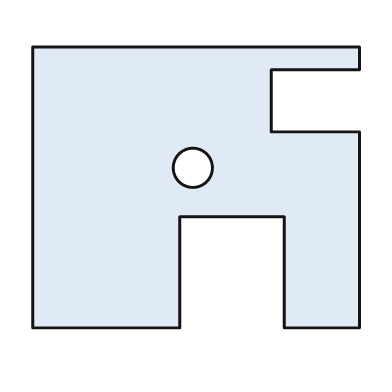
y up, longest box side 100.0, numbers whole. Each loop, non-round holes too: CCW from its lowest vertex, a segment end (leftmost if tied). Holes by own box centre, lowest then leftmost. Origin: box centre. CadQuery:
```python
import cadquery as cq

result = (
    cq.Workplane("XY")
    .moveTo(-50.0, -43.0)
    .lineTo(-5.0, -43.0)
    .lineTo(-5.0, -9.0)
    .lineTo(27.0, -9.0)
    .lineTo(27.0, -43.0)
    .lineTo(50.0, -43.0)
    .lineTo(50.0, 17.0)
    .lineTo(23.0, 17.0)
    .lineTo(23.0, 36.0)
    .lineTo(50.0, 36.0)
    .lineTo(50.0, 43.0)
    .lineTo(-50.0, 43.0)
    .close()
    .moveTo(-1.0, 6.0)
    .circle(6.0)
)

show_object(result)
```